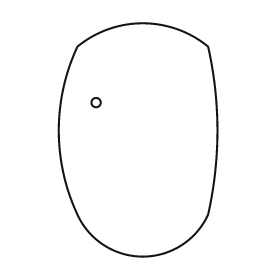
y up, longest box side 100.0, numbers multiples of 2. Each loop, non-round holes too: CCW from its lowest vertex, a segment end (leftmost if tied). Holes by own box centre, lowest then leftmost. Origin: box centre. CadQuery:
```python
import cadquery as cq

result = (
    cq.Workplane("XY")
    .moveTo(-26.0, -32.0)
    .threePointArc((2.0, -50.0), (30.0, -32.0))
    .threePointArc((34.0, 4.0), (30.0, 40.0))
    .threePointArc((2.0, 50.0), (-26.0, 40.0))
    .threePointArc((-34.0, 4.0), (-26.0, -32.0))
    .close()
    .moveTo(-18.0, 16.0)
    .circle(2.0)
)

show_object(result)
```